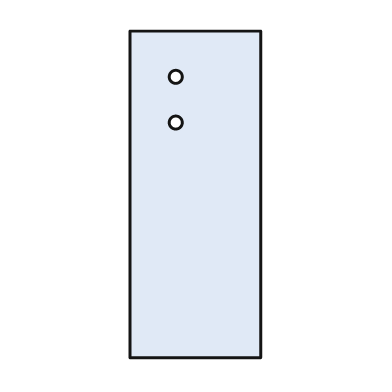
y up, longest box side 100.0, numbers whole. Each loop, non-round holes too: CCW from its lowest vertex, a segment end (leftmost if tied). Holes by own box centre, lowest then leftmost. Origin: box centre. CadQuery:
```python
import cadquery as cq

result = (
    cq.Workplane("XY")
    .moveTo(-20.0, -50.0)
    .lineTo(20.0, -50.0)
    .lineTo(20.0, 50.0)
    .lineTo(-20.0, 50.0)
    .close()
    .moveTo(-6.0, 22.0)
    .circle(2.0)
    .moveTo(-6.0, 36.0)
    .circle(2.0)
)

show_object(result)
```